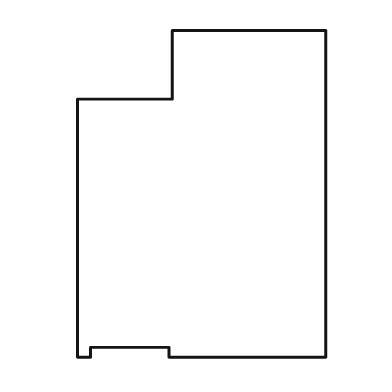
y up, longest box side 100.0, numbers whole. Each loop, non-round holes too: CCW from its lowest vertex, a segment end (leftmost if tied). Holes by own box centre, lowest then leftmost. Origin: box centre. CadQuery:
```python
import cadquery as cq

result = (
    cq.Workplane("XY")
    .moveTo(-38.0, -50.0)
    .lineTo(-34.0, -50.0)
    .lineTo(-34.0, -47.0)
    .lineTo(-10.0, -47.0)
    .lineTo(-10.0, -50.0)
    .lineTo(38.0, -50.0)
    .lineTo(38.0, 50.0)
    .lineTo(-9.0, 50.0)
    .lineTo(-9.0, 29.0)
    .lineTo(-38.0, 29.0)
    .close()
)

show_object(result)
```